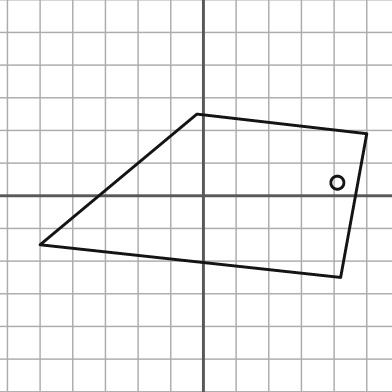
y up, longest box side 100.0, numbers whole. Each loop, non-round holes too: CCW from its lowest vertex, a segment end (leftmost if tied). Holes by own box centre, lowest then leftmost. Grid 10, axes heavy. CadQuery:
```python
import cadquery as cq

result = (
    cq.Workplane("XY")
    .moveTo(42.0, -25.0)
    .lineTo(50.0, 19.0)
    .lineTo(-2.0, 25.0)
    .lineTo(-50.0, -15.0)
    .close()
    .moveTo(41.0, 4.0)
    .circle(2.0)
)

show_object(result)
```